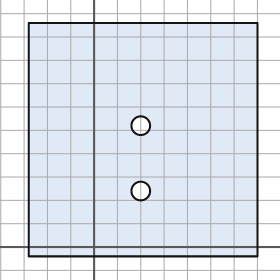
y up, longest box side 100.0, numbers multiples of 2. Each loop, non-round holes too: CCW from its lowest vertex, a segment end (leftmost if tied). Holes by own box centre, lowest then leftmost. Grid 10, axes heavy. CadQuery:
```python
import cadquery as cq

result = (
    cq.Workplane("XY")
    .moveTo(-28.0, -4.0)
    .lineTo(70.0, -4.0)
    .lineTo(70.0, 96.0)
    .lineTo(-28.0, 96.0)
    .close()
    .moveTo(20.0, 24.0)
    .circle(4.0)
    .moveTo(20.0, 52.0)
    .circle(4.0)
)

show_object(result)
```